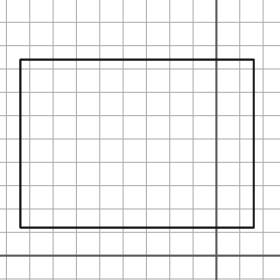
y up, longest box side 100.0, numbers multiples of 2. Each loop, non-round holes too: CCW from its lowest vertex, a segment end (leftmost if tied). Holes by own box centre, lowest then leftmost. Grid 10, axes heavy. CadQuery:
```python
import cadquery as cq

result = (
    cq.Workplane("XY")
    .moveTo(-84.0, 12.0)
    .lineTo(16.0, 12.0)
    .lineTo(16.0, 84.0)
    .lineTo(-84.0, 84.0)
    .close()
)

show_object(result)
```